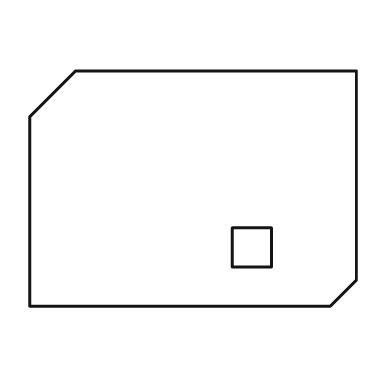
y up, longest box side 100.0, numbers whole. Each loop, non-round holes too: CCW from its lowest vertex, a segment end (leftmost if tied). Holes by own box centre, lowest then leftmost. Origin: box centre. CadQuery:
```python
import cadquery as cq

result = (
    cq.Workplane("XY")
    .moveTo(-50.0, -36.0)
    .lineTo(42.0, -36.0)
    .lineTo(50.0, -28.0)
    .lineTo(50.0, 36.0)
    .lineTo(-36.0, 36.0)
    .lineTo(-50.0, 22.0)
    .close()
    .moveTo(12.0, -24.0)
    .lineTo(24.0, -24.0)
    .lineTo(24.0, -12.0)
    .lineTo(12.0, -12.0)
    .close()
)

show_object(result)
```